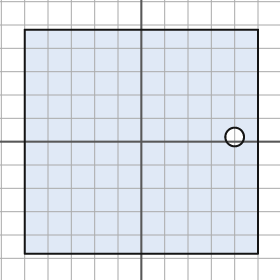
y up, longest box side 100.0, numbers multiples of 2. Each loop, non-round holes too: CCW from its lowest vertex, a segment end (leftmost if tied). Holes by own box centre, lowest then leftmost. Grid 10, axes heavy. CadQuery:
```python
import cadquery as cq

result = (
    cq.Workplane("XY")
    .moveTo(-50.0, -48.0)
    .lineTo(50.0, -48.0)
    .lineTo(50.0, 48.0)
    .lineTo(-50.0, 48.0)
    .close()
    .moveTo(40.0, 2.0)
    .circle(4.0)
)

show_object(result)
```